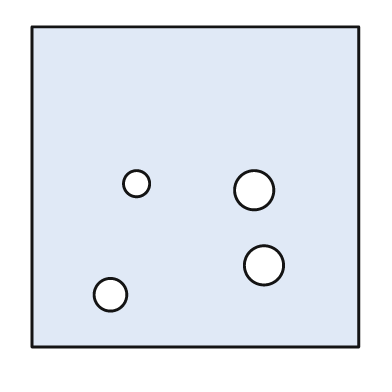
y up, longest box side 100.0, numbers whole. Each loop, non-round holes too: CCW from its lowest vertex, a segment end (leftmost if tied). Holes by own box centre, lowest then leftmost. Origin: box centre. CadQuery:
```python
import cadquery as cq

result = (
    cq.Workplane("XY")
    .moveTo(-50.0, -49.0)
    .lineTo(50.0, -49.0)
    .lineTo(50.0, 49.0)
    .lineTo(-50.0, 49.0)
    .close()
    .moveTo(-26.0, -33.0)
    .circle(5.0)
    .moveTo(21.0, -24.0)
    .circle(6.0)
    .moveTo(18.0, -1.0)
    .circle(6.0)
    .moveTo(-18.0, 1.0)
    .circle(4.0)
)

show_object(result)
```